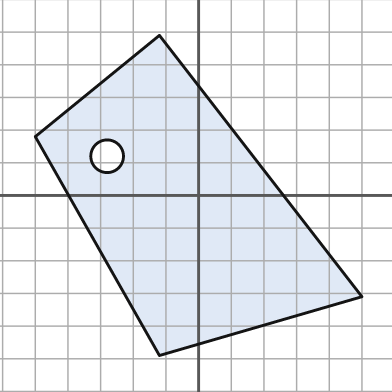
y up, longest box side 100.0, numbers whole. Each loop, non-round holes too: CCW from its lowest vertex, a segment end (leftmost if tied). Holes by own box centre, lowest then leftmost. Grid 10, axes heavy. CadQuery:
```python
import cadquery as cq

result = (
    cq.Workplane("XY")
    .moveTo(-12.0, -49.0)
    .lineTo(50.0, -31.0)
    .lineTo(-12.0, 49.0)
    .lineTo(-50.0, 18.0)
    .close()
    .moveTo(-28.0, 12.0)
    .circle(5.0)
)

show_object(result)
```